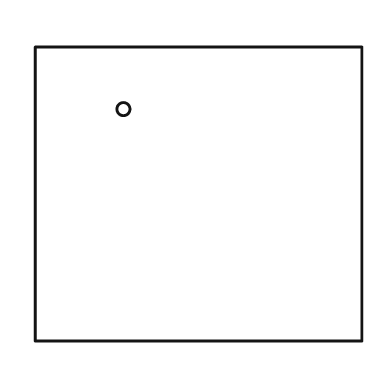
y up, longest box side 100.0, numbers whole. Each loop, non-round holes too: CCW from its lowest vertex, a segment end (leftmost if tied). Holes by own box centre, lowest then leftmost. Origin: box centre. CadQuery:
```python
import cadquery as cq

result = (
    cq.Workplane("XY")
    .moveTo(-50.0, -45.0)
    .lineTo(50.0, -45.0)
    .lineTo(50.0, 45.0)
    .lineTo(-50.0, 45.0)
    .close()
    .moveTo(-23.0, 26.0)
    .circle(2.0)
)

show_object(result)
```